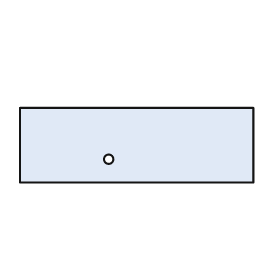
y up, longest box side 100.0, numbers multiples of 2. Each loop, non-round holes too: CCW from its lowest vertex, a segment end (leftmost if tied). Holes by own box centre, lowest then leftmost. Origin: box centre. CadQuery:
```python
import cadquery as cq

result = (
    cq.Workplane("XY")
    .moveTo(-50.0, -16.0)
    .lineTo(50.0, -16.0)
    .lineTo(50.0, 16.0)
    .lineTo(-50.0, 16.0)
    .close()
    .moveTo(-12.0, -6.0)
    .circle(2.0)
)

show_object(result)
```